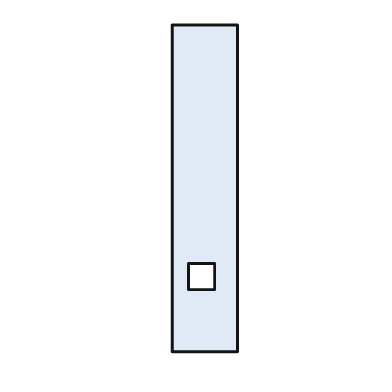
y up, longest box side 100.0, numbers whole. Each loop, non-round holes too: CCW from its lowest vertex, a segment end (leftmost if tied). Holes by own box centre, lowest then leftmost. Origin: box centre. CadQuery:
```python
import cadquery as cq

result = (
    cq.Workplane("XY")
    .moveTo(-10.0, -50.0)
    .lineTo(10.0, -50.0)
    .lineTo(10.0, 50.0)
    .lineTo(-10.0, 50.0)
    .close()
    .moveTo(-5.0, -31.0)
    .lineTo(3.0, -31.0)
    .lineTo(3.0, -23.0)
    .lineTo(-5.0, -23.0)
    .close()
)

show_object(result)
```